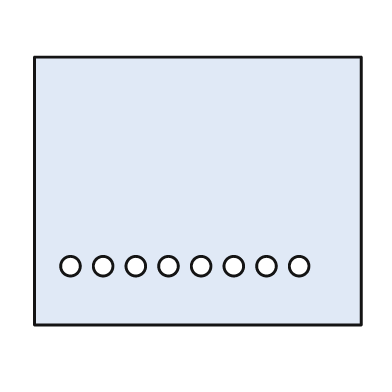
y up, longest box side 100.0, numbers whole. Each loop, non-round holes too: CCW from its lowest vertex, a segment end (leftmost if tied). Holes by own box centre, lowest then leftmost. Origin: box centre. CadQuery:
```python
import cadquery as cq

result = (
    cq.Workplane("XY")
    .moveTo(-50.0, -41.0)
    .lineTo(50.0, -41.0)
    .lineTo(50.0, 41.0)
    .lineTo(-50.0, 41.0)
    .close()
    .moveTo(-39.0, -23.0)
    .circle(3.0)
    .moveTo(-29.0, -23.0)
    .circle(3.0)
    .moveTo(-19.0, -23.0)
    .circle(3.0)
    .moveTo(-9.0, -23.0)
    .circle(3.0)
    .moveTo(1.0, -23.0)
    .circle(3.0)
    .moveTo(11.0, -23.0)
    .circle(3.0)
    .moveTo(21.0, -23.0)
    .circle(3.0)
    .moveTo(31.0, -23.0)
    .circle(3.0)
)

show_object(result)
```